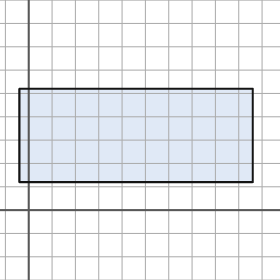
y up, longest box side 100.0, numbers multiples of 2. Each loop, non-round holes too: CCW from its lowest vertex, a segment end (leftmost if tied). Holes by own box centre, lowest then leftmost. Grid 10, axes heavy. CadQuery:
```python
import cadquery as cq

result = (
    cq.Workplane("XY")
    .moveTo(-4.0, 12.0)
    .lineTo(96.0, 12.0)
    .lineTo(96.0, 52.0)
    .lineTo(-4.0, 52.0)
    .close()
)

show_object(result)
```